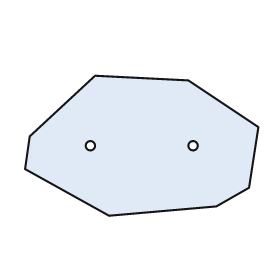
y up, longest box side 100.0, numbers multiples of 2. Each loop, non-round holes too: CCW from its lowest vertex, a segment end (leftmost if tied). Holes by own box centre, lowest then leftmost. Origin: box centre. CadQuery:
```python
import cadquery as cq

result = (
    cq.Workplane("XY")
    .moveTo(-14.0, -30.0)
    .lineTo(32.0, -26.0)
    .lineTo(46.0, -18.0)
    .lineTo(50.0, 8.0)
    .lineTo(20.0, 28.0)
    .lineTo(-20.0, 30.0)
    .lineTo(-48.0, 4.0)
    .lineTo(-50.0, -10.0)
    .close()
    .moveTo(-22.0, 0.0)
    .circle(2.0)
    .moveTo(22.0, 0.0)
    .circle(2.0)
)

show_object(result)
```